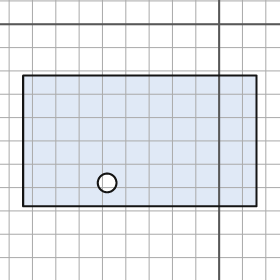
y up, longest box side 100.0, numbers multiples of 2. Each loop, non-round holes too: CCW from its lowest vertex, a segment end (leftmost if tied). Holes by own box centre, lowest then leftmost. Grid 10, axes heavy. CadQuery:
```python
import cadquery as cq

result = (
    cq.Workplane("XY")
    .moveTo(-84.0, -78.0)
    .lineTo(16.0, -78.0)
    .lineTo(16.0, -22.0)
    .lineTo(-84.0, -22.0)
    .close()
    .moveTo(-48.0, -68.0)
    .circle(4.0)
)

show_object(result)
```